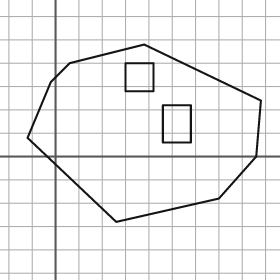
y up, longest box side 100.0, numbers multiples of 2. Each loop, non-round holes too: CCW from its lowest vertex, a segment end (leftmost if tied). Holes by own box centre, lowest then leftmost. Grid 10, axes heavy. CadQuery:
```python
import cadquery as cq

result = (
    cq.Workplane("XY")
    .moveTo(26.0, -28.0)
    .lineTo(70.0, -18.0)
    .lineTo(86.0, 0.0)
    .lineTo(88.0, 24.0)
    .lineTo(38.0, 48.0)
    .lineTo(6.0, 40.0)
    .lineTo(-2.0, 32.0)
    .lineTo(-12.0, 8.0)
    .close()
    .moveTo(46.0, 6.0)
    .lineTo(58.0, 6.0)
    .lineTo(58.0, 22.0)
    .lineTo(46.0, 22.0)
    .close()
    .moveTo(30.0, 28.0)
    .lineTo(42.0, 28.0)
    .lineTo(42.0, 40.0)
    .lineTo(30.0, 40.0)
    .close()
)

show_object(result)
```